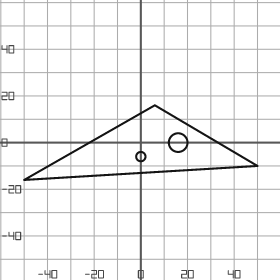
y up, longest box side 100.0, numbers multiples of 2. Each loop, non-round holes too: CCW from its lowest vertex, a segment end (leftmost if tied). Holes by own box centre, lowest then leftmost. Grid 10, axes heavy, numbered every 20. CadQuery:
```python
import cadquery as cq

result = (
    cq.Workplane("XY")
    .moveTo(-50.0, -16.0)
    .lineTo(50.0, -10.0)
    .lineTo(6.0, 16.0)
    .close()
    .moveTo(0.0, -6.0)
    .circle(2.0)
    .moveTo(16.0, 0.0)
    .circle(4.0)
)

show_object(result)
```